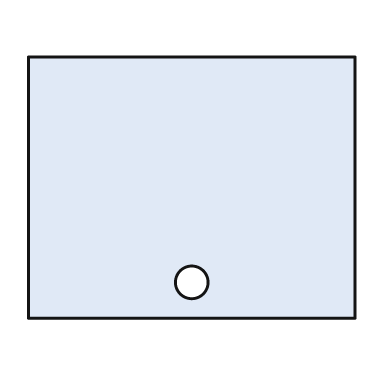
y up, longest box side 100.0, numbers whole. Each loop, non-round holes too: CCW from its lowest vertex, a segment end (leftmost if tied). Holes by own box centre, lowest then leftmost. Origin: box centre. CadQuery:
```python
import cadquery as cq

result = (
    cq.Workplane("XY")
    .moveTo(-50.0, -40.0)
    .lineTo(50.0, -40.0)
    .lineTo(50.0, 40.0)
    .lineTo(-50.0, 40.0)
    .close()
    .moveTo(0.0, -29.0)
    .circle(5.0)
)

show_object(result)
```